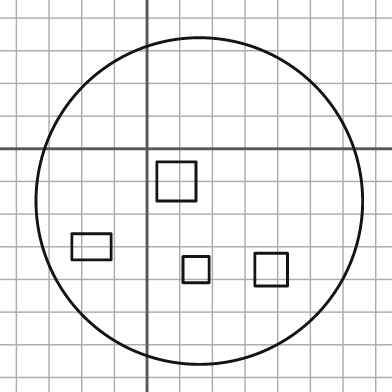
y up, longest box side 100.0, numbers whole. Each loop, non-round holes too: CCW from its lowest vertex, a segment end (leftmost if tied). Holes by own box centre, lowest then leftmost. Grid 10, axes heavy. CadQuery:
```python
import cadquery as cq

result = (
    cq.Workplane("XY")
    .moveTo(16.0, -16.0)
    .circle(50.0)
    .moveTo(11.0, -41.0)
    .lineTo(19.0, -41.0)
    .lineTo(19.0, -33.0)
    .lineTo(11.0, -33.0)
    .close()
    .moveTo(33.0, -42.0)
    .lineTo(43.0, -42.0)
    .lineTo(43.0, -32.0)
    .lineTo(33.0, -32.0)
    .close()
    .moveTo(-23.0, -34.0)
    .lineTo(-11.0, -34.0)
    .lineTo(-11.0, -26.0)
    .lineTo(-23.0, -26.0)
    .close()
    .moveTo(3.0, -16.0)
    .lineTo(15.0, -16.0)
    .lineTo(15.0, -4.0)
    .lineTo(3.0, -4.0)
    .close()
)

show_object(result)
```